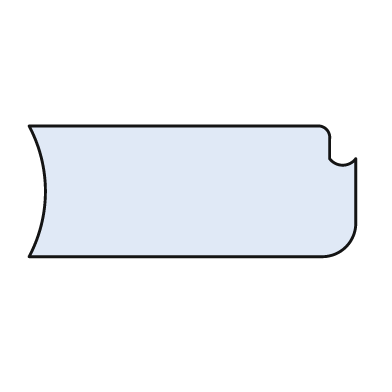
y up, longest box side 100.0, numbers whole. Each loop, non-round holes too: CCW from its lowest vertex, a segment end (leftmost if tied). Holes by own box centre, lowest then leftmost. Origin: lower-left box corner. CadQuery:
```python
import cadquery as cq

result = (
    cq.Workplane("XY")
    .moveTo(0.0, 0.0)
    .lineTo(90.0, 0.0)
    .threePointArc((97.0, 3.0), (100.0, 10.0))
    .lineTo(100.0, 30.0)
    .threePointArc((96.0, 28.0), (92.0, 30.0))
    .lineTo(92.0, 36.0)
    .threePointArc((91.0, 39.0), (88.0, 40.0))
    .lineTo(0.0, 40.0)
    .threePointArc((5.0, 20.0), (0.0, 0.0))
    .close()
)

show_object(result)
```